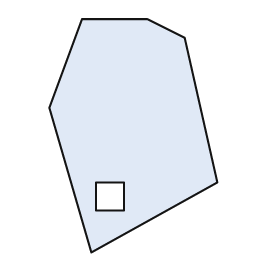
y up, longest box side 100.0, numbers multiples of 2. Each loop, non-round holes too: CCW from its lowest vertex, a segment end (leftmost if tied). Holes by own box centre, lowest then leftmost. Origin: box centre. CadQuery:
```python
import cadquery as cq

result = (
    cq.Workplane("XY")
    .moveTo(-18.0, -50.0)
    .lineTo(36.0, -20.0)
    .lineTo(22.0, 42.0)
    .lineTo(6.0, 50.0)
    .lineTo(-22.0, 50.0)
    .lineTo(-36.0, 12.0)
    .close()
    .moveTo(-16.0, -32.0)
    .lineTo(-4.0, -32.0)
    .lineTo(-4.0, -20.0)
    .lineTo(-16.0, -20.0)
    .close()
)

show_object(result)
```